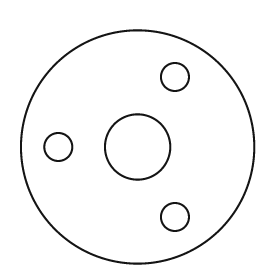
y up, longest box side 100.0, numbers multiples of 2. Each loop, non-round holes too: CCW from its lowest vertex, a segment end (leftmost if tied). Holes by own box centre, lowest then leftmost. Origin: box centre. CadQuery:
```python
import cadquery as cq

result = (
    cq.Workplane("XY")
    .moveTo(0.0, 0.0)
    .circle(50.0)
    .moveTo(16.0, -30.0)
    .circle(6.0)
    .moveTo(-34.0, 0.0)
    .circle(6.0)
    .moveTo(0.0, 0.0)
    .circle(14.0)
    .moveTo(16.0, 30.0)
    .circle(6.0)
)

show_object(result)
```